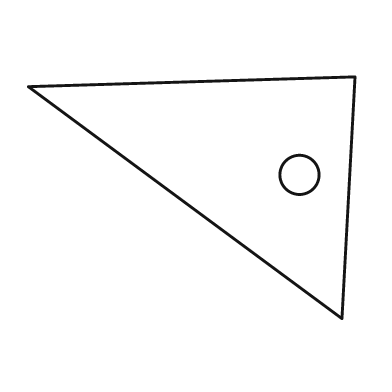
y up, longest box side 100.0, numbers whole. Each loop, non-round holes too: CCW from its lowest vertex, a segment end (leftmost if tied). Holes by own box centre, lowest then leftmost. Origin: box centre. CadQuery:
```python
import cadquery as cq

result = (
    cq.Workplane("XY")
    .moveTo(46.0, -37.0)
    .lineTo(50.0, 37.0)
    .lineTo(-50.0, 34.0)
    .close()
    .moveTo(33.0, 7.0)
    .circle(6.0)
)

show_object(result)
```